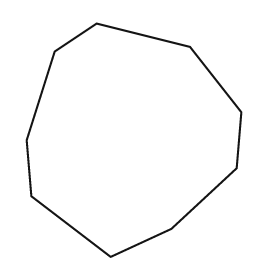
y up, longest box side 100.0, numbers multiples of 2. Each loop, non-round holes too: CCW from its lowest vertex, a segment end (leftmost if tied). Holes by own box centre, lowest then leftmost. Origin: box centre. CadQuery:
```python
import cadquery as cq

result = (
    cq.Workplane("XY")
    .moveTo(-10.0, -50.0)
    .lineTo(16.0, -38.0)
    .lineTo(44.0, -12.0)
    .lineTo(46.0, 12.0)
    .lineTo(24.0, 40.0)
    .lineTo(-16.0, 50.0)
    .lineTo(-34.0, 38.0)
    .lineTo(-46.0, 0.0)
    .lineTo(-44.0, -24.0)
    .close()
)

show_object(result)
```